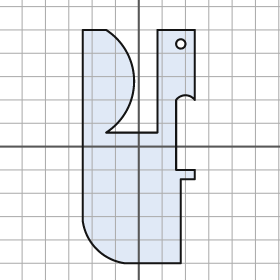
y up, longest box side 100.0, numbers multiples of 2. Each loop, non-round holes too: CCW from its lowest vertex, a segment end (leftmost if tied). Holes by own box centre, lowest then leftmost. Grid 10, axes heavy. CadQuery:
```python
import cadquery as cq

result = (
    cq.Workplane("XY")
    .moveTo(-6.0, -50.0)
    .lineTo(18.0, -50.0)
    .lineTo(18.0, -14.0)
    .lineTo(24.0, -14.0)
    .lineTo(24.0, -10.0)
    .lineTo(16.0, -10.0)
    .lineTo(16.0, 20.0)
    .threePointArc((20.0, 22.0), (24.0, 20.0))
    .lineTo(24.0, 50.0)
    .lineTo(8.0, 50.0)
    .lineTo(8.0, 6.0)
    .lineTo(-14.0, 6.0)
    .threePointArc((-2.0, 28.0), (-14.0, 50.0))
    .lineTo(-24.0, 50.0)
    .lineTo(-24.0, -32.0)
    .threePointArc((-18.0, -44.0), (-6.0, -50.0))
    .close()
    .moveTo(18.0, 44.0)
    .circle(2.0)
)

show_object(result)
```